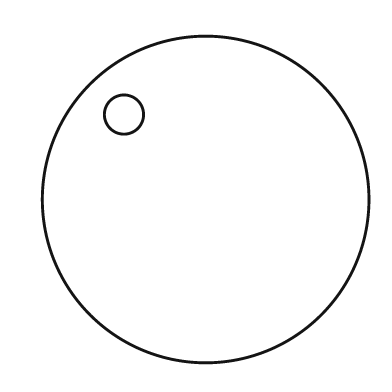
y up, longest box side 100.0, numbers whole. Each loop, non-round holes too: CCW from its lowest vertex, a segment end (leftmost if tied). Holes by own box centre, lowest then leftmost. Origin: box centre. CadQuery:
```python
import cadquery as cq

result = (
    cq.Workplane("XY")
    .moveTo(0.0, 0.0)
    .circle(50.0)
    .moveTo(-25.0, 26.0)
    .circle(6.0)
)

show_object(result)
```